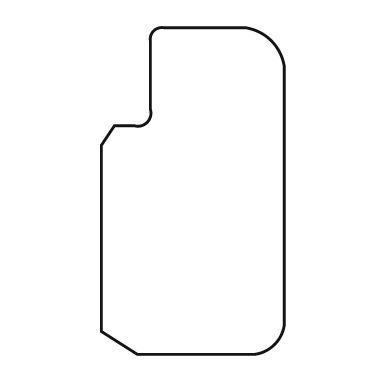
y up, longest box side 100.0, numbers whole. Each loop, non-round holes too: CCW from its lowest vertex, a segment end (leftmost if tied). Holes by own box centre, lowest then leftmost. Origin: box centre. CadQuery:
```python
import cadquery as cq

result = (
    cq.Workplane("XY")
    .moveTo(-17.0, -50.0)
    .lineTo(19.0, -50.0)
    .threePointArc((25.0, -47.0), (28.0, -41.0))
    .lineTo(28.0, 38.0)
    .threePointArc((24.0, 46.0), (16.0, 50.0))
    .lineTo(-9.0, 50.0)
    .threePointArc((-12.0, 49.0), (-13.0, 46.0))
    .lineTo(-13.0, 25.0)
    .threePointArc((-14.0, 21.0), (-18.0, 20.0))
    .lineTo(-24.0, 20.0)
    .lineTo(-28.0, 14.0)
    .lineTo(-28.0, -43.0)
    .close()
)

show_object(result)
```